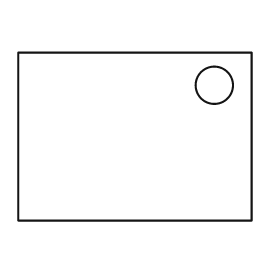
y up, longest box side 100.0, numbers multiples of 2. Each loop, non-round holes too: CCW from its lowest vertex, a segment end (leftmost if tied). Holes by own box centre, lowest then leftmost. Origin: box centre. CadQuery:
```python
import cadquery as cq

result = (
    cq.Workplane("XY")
    .moveTo(-50.0, -36.0)
    .lineTo(50.0, -36.0)
    .lineTo(50.0, 36.0)
    .lineTo(-50.0, 36.0)
    .close()
    .moveTo(34.0, 22.0)
    .circle(8.0)
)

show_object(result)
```